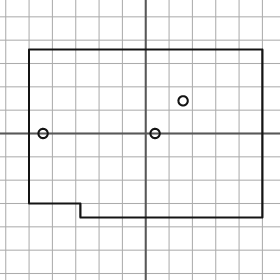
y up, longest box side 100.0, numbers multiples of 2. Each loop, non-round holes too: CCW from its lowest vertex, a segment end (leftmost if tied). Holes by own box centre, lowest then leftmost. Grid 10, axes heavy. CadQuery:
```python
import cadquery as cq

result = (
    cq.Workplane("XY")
    .moveTo(-28.0, -36.0)
    .lineTo(50.0, -36.0)
    .lineTo(50.0, 36.0)
    .lineTo(-50.0, 36.0)
    .lineTo(-50.0, -30.0)
    .lineTo(-28.0, -30.0)
    .close()
    .moveTo(-44.0, 0.0)
    .circle(2.0)
    .moveTo(4.0, 0.0)
    .circle(2.0)
    .moveTo(16.0, 14.0)
    .circle(2.0)
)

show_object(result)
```